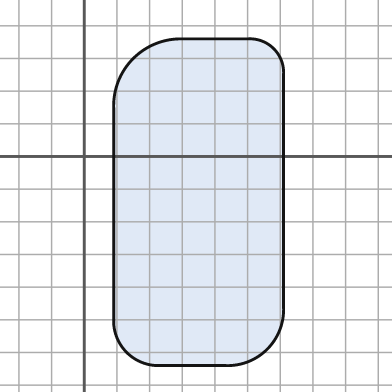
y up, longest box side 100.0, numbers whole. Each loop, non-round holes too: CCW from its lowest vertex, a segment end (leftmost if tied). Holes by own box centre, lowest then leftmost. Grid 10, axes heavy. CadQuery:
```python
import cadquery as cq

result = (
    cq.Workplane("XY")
    .moveTo(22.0, -64.0)
    .lineTo(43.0, -64.0)
    .threePointArc((56.0, -59.0), (61.0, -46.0))
    .lineTo(61.0, 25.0)
    .threePointArc((58.0, 33.0), (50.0, 36.0))
    .lineTo(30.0, 36.0)
    .threePointArc((15.0, 30.0), (9.0, 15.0))
    .lineTo(9.0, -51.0)
    .threePointArc((13.0, -60.0), (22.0, -64.0))
    .close()
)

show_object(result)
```